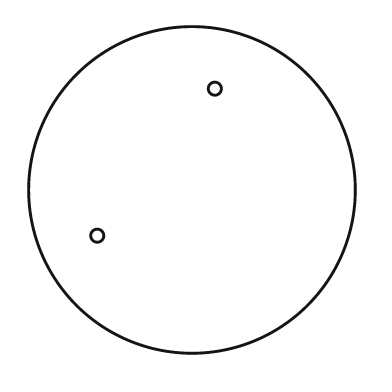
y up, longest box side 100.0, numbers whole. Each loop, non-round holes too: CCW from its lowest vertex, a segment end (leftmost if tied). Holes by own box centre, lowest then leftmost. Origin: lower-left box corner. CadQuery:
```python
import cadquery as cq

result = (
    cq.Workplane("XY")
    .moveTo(50.0, 50.0)
    .circle(50.0)
    .moveTo(21.0, 36.0)
    .circle(2.0)
    .moveTo(57.0, 81.0)
    .circle(2.0)
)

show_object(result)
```